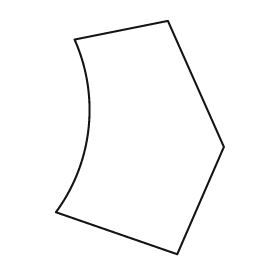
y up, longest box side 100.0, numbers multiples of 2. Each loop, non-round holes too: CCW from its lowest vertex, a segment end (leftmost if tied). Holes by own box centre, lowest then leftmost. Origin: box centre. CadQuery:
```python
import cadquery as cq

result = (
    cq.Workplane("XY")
    .moveTo(16.0, -50.0)
    .lineTo(36.0, -4.0)
    .lineTo(12.0, 50.0)
    .lineTo(-28.0, 42.0)
    .threePointArc((-22.0, 4.0), (-36.0, -32.0))
    .close()
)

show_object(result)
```